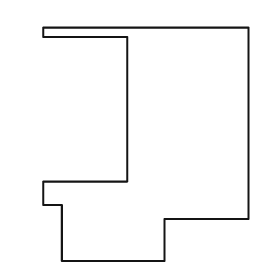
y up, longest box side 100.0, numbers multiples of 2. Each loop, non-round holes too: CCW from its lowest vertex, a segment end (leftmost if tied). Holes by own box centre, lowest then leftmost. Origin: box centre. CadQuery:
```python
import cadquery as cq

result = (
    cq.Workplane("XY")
    .moveTo(-36.0, -50.0)
    .lineTo(8.0, -50.0)
    .lineTo(8.0, -32.0)
    .lineTo(44.0, -32.0)
    .lineTo(44.0, 50.0)
    .lineTo(-44.0, 50.0)
    .lineTo(-44.0, 46.0)
    .lineTo(-8.0, 46.0)
    .lineTo(-8.0, -16.0)
    .lineTo(-44.0, -16.0)
    .lineTo(-44.0, -26.0)
    .lineTo(-36.0, -26.0)
    .close()
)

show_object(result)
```